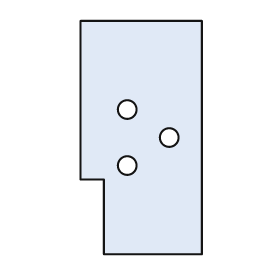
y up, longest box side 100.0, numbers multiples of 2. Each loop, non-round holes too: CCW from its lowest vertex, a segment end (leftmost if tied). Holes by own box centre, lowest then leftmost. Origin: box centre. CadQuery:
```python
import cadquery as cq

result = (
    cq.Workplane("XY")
    .moveTo(-16.0, -50.0)
    .lineTo(26.0, -50.0)
    .lineTo(26.0, 50.0)
    .lineTo(-26.0, 50.0)
    .lineTo(-26.0, -18.0)
    .lineTo(-16.0, -18.0)
    .close()
    .moveTo(-6.0, -12.0)
    .circle(4.0)
    .moveTo(12.0, 0.0)
    .circle(4.0)
    .moveTo(-6.0, 12.0)
    .circle(4.0)
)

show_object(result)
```